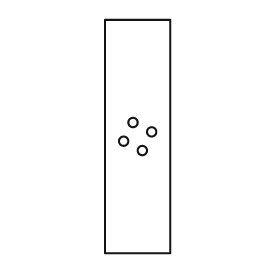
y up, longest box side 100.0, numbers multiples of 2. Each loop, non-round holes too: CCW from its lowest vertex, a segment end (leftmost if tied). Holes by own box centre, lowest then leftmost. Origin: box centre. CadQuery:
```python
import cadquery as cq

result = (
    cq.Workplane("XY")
    .moveTo(-14.0, -50.0)
    .lineTo(14.0, -50.0)
    .lineTo(14.0, 50.0)
    .lineTo(-14.0, 50.0)
    .close()
    .moveTo(2.0, -6.0)
    .circle(2.0)
    .moveTo(-6.0, -2.0)
    .circle(2.0)
    .moveTo(6.0, 2.0)
    .circle(2.0)
    .moveTo(-2.0, 6.0)
    .circle(2.0)
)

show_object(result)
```